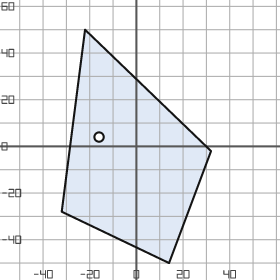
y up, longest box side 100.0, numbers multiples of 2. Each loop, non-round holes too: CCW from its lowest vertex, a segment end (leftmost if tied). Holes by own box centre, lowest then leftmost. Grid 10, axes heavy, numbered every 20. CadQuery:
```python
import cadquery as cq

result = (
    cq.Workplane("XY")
    .moveTo(14.0, -50.0)
    .lineTo(32.0, -2.0)
    .lineTo(-22.0, 50.0)
    .lineTo(-32.0, -28.0)
    .close()
    .moveTo(-16.0, 4.0)
    .circle(2.0)
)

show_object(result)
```